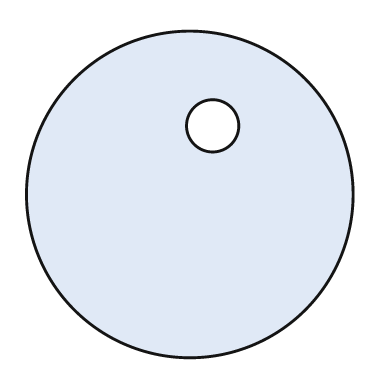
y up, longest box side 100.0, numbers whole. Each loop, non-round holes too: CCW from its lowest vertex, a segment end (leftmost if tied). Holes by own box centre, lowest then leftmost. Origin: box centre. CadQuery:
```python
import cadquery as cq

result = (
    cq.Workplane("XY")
    .moveTo(0.0, 0.0)
    .circle(50.0)
    .moveTo(7.0, 21.0)
    .circle(8.0)
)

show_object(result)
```